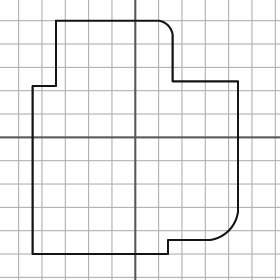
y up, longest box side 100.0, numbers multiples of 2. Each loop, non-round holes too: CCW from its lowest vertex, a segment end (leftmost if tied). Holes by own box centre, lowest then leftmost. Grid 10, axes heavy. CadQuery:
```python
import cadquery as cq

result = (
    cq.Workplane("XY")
    .moveTo(-44.0, -50.0)
    .lineTo(14.0, -50.0)
    .lineTo(14.0, -44.0)
    .lineTo(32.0, -44.0)
    .threePointArc((40.0, -40.0), (44.0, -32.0))
    .lineTo(44.0, 24.0)
    .lineTo(16.0, 24.0)
    .lineTo(16.0, 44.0)
    .threePointArc((14.0, 48.0), (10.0, 50.0))
    .lineTo(-34.0, 50.0)
    .lineTo(-34.0, 22.0)
    .lineTo(-44.0, 22.0)
    .close()
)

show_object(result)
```